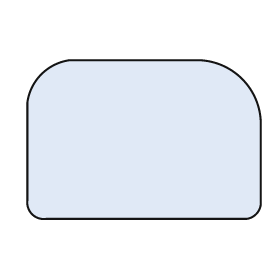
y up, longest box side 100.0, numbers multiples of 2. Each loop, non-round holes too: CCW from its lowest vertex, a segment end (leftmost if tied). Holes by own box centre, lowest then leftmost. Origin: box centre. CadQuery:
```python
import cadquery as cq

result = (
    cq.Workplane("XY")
    .moveTo(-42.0, -34.0)
    .lineTo(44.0, -34.0)
    .threePointArc((48.0, -32.0), (50.0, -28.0))
    .lineTo(50.0, 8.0)
    .threePointArc((42.0, 26.0), (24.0, 34.0))
    .lineTo(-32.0, 34.0)
    .threePointArc((-44.0, 28.0), (-50.0, 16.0))
    .lineTo(-50.0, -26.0)
    .threePointArc((-48.0, -32.0), (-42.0, -34.0))
    .close()
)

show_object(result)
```